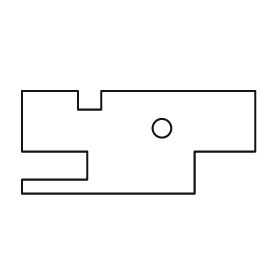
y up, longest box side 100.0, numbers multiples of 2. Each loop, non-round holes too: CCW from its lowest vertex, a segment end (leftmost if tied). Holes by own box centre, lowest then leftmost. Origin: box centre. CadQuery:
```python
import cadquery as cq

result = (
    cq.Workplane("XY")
    .moveTo(-50.0, -22.0)
    .lineTo(24.0, -22.0)
    .lineTo(24.0, -4.0)
    .lineTo(50.0, -4.0)
    .lineTo(50.0, 22.0)
    .lineTo(-16.0, 22.0)
    .lineTo(-16.0, 14.0)
    .lineTo(-26.0, 14.0)
    .lineTo(-26.0, 22.0)
    .lineTo(-50.0, 22.0)
    .lineTo(-50.0, -4.0)
    .lineTo(-22.0, -4.0)
    .lineTo(-22.0, -16.0)
    .lineTo(-50.0, -16.0)
    .close()
    .moveTo(10.0, 6.0)
    .circle(4.0)
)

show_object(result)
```